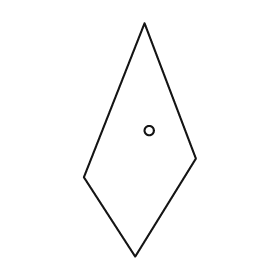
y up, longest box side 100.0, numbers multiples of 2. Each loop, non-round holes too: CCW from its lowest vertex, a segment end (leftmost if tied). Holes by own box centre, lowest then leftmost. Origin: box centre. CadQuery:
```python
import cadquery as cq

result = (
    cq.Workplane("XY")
    .moveTo(-2.0, -50.0)
    .lineTo(24.0, -8.0)
    .lineTo(2.0, 50.0)
    .lineTo(-24.0, -16.0)
    .close()
    .moveTo(4.0, 4.0)
    .circle(2.0)
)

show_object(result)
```